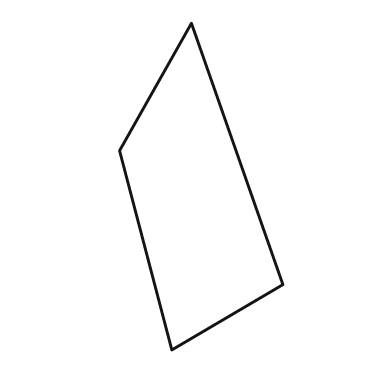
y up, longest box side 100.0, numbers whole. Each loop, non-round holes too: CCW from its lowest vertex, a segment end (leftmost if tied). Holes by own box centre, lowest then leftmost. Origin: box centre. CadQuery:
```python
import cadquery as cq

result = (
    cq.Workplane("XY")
    .moveTo(-9.0, -50.0)
    .lineTo(25.0, -30.0)
    .lineTo(-3.0, 50.0)
    .lineTo(-25.0, 11.0)
    .close()
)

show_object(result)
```